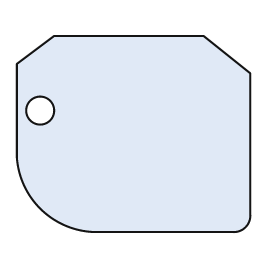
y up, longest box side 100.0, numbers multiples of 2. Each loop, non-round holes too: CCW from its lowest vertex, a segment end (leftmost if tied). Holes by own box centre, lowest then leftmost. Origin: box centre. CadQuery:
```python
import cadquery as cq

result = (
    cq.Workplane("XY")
    .moveTo(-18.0, -42.0)
    .lineTo(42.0, -42.0)
    .threePointArc((48.0, -40.0), (50.0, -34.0))
    .lineTo(50.0, 26.0)
    .lineTo(30.0, 42.0)
    .lineTo(-34.0, 42.0)
    .lineTo(-50.0, 30.0)
    .lineTo(-50.0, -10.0)
    .threePointArc((-40.0, -32.0), (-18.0, -42.0))
    .close()
    .moveTo(-40.0, 10.0)
    .circle(6.0)
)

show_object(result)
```